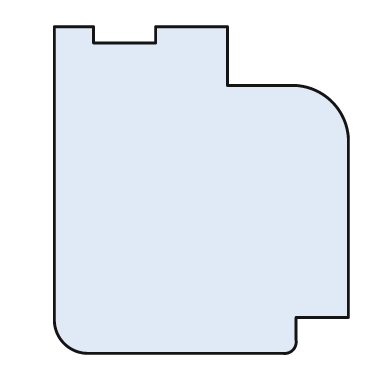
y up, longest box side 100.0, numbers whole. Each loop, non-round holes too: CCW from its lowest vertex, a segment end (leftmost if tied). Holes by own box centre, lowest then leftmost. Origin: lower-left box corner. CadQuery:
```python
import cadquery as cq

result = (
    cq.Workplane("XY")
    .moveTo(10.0, 0.0)
    .lineTo(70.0, 0.0)
    .threePointArc((73.0, 1.0), (74.0, 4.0))
    .lineTo(74.0, 11.0)
    .lineTo(90.0, 11.0)
    .lineTo(90.0, 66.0)
    .threePointArc((85.0, 77.0), (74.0, 82.0))
    .lineTo(53.0, 82.0)
    .lineTo(53.0, 100.0)
    .lineTo(31.0, 100.0)
    .lineTo(31.0, 95.0)
    .lineTo(12.0, 95.0)
    .lineTo(12.0, 100.0)
    .lineTo(0.0, 100.0)
    .lineTo(0.0, 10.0)
    .threePointArc((3.0, 3.0), (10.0, 0.0))
    .close()
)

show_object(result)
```